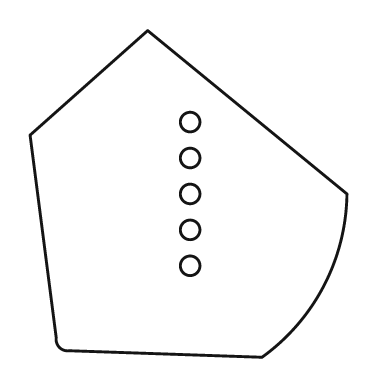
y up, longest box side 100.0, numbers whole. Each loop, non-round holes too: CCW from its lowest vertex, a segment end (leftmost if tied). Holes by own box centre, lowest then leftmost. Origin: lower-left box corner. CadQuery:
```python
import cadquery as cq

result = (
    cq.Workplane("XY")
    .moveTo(71.0, 0.0)
    .threePointArc((90.0, 22.0), (97.0, 50.0))
    .lineTo(36.0, 100.0)
    .lineTo(0.0, 68.0)
    .lineTo(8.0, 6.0)
    .threePointArc((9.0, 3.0), (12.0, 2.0))
    .close()
    .moveTo(49.0, 28.0)
    .circle(3.0)
    .moveTo(49.0, 39.0)
    .circle(3.0)
    .moveTo(49.0, 50.0)
    .circle(3.0)
    .moveTo(49.0, 61.0)
    .circle(3.0)
    .moveTo(49.0, 72.0)
    .circle(3.0)
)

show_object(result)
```